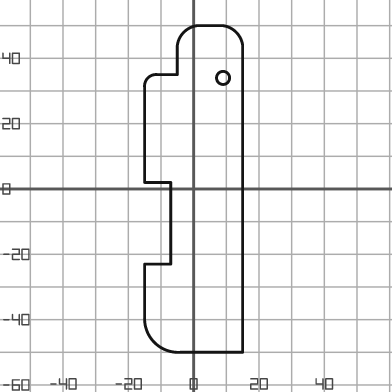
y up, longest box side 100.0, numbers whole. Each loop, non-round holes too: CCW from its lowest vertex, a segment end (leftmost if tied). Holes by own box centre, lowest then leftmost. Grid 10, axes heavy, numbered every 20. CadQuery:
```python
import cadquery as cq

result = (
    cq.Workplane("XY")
    .moveTo(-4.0, -50.0)
    .lineTo(15.0, -50.0)
    .lineTo(15.0, 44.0)
    .threePointArc((13.0, 48.0), (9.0, 50.0))
    .lineTo(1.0, 50.0)
    .threePointArc((-3.0, 48.0), (-5.0, 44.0))
    .lineTo(-5.0, 35.0)
    .lineTo(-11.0, 35.0)
    .threePointArc((-14.0, 34.0), (-15.0, 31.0))
    .lineTo(-15.0, 2.0)
    .lineTo(-7.0, 2.0)
    .lineTo(-7.0, -23.0)
    .lineTo(-15.0, -23.0)
    .lineTo(-15.0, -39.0)
    .threePointArc((-12.0, -47.0), (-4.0, -50.0))
    .close()
    .moveTo(9.0, 34.0)
    .circle(2.0)
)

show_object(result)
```